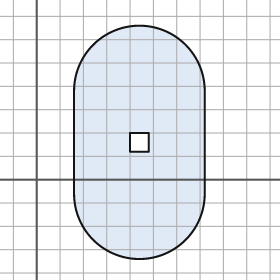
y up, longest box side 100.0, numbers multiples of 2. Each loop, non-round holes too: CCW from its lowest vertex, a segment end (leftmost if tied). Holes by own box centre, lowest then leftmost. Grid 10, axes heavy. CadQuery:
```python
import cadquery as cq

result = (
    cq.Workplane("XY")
    .moveTo(16.0, -6.0)
    .threePointArc((44.0, -34.0), (72.0, -6.0))
    .lineTo(72.0, 38.0)
    .threePointArc((44.0, 66.0), (16.0, 38.0))
    .close()
    .moveTo(40.0, 12.0)
    .lineTo(48.0, 12.0)
    .lineTo(48.0, 20.0)
    .lineTo(40.0, 20.0)
    .close()
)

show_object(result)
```